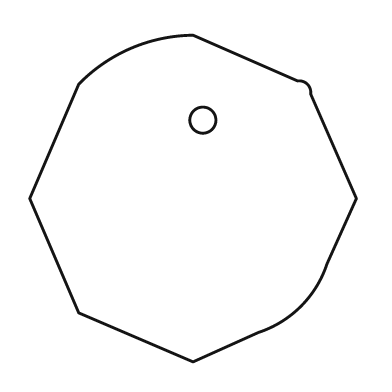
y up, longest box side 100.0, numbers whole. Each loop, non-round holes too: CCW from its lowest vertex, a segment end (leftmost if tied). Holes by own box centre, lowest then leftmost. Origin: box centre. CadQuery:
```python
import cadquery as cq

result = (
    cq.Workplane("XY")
    .moveTo(0.0, -50.0)
    .lineTo(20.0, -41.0)
    .threePointArc((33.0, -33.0), (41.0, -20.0))
    .lineTo(50.0, 0.0)
    .lineTo(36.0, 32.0)
    .threePointArc((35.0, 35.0), (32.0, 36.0))
    .lineTo(0.0, 50.0)
    .threePointArc((-19.0, 46.0), (-35.0, 35.0))
    .lineTo(-50.0, 0.0)
    .lineTo(-35.0, -35.0)
    .close()
    .moveTo(3.0, 24.0)
    .circle(4.0)
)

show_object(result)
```